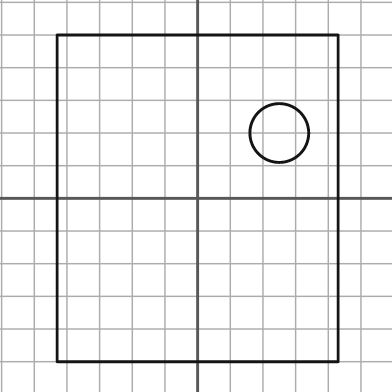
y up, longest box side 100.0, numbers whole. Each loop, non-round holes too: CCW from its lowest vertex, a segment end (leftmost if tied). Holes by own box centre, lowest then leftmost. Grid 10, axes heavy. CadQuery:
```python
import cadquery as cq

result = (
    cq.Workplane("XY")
    .moveTo(-43.0, -50.0)
    .lineTo(43.0, -50.0)
    .lineTo(43.0, 50.0)
    .lineTo(-43.0, 50.0)
    .close()
    .moveTo(25.0, 20.0)
    .circle(9.0)
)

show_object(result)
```